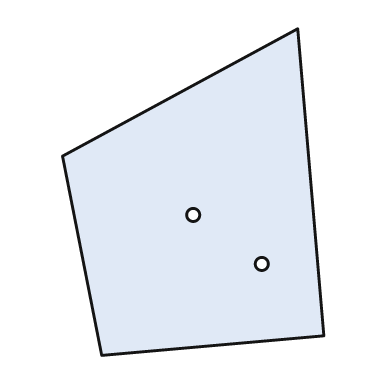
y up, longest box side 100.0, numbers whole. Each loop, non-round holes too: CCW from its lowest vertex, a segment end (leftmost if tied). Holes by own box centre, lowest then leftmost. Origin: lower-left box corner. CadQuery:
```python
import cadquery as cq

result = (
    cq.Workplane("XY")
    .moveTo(12.0, 0.0)
    .lineTo(80.0, 6.0)
    .lineTo(72.0, 100.0)
    .lineTo(0.0, 61.0)
    .close()
    .moveTo(61.0, 28.0)
    .circle(2.0)
    .moveTo(40.0, 43.0)
    .circle(2.0)
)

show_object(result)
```